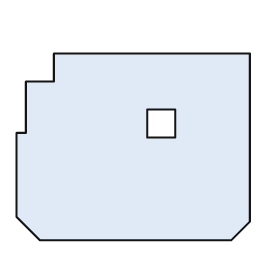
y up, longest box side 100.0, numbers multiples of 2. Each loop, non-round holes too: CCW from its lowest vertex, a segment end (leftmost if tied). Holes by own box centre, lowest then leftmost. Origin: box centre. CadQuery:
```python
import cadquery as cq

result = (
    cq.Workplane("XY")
    .moveTo(-40.0, -40.0)
    .lineTo(42.0, -40.0)
    .lineTo(50.0, -32.0)
    .lineTo(50.0, 40.0)
    .lineTo(-34.0, 40.0)
    .lineTo(-34.0, 28.0)
    .lineTo(-46.0, 28.0)
    .lineTo(-46.0, 6.0)
    .lineTo(-50.0, 6.0)
    .lineTo(-50.0, -30.0)
    .close()
    .moveTo(6.0, 4.0)
    .lineTo(18.0, 4.0)
    .lineTo(18.0, 16.0)
    .lineTo(6.0, 16.0)
    .close()
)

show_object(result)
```